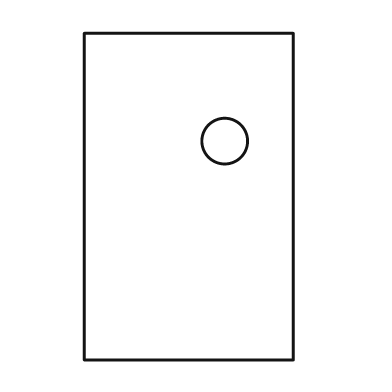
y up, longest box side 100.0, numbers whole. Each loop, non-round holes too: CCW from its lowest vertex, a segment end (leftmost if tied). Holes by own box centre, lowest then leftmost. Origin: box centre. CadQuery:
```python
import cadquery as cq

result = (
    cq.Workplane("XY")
    .moveTo(-32.0, -50.0)
    .lineTo(32.0, -50.0)
    .lineTo(32.0, 50.0)
    .lineTo(-32.0, 50.0)
    .close()
    .moveTo(11.0, 17.0)
    .circle(7.0)
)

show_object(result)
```